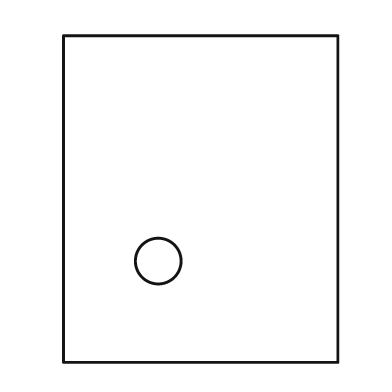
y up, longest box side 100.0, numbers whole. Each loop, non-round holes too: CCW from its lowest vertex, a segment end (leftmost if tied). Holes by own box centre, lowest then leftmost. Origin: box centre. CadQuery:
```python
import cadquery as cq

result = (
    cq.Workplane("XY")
    .moveTo(-42.0, -50.0)
    .lineTo(42.0, -50.0)
    .lineTo(42.0, 50.0)
    .lineTo(-42.0, 50.0)
    .close()
    .moveTo(-13.0, -19.0)
    .circle(7.0)
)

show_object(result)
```